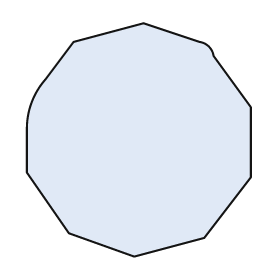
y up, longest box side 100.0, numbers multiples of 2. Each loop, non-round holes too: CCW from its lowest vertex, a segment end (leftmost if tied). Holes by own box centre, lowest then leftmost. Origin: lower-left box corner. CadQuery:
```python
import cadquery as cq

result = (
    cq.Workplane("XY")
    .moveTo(46.0, 0.0)
    .lineTo(76.0, 8.0)
    .lineTo(96.0, 34.0)
    .lineTo(96.0, 64.0)
    .lineTo(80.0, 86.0)
    .threePointArc((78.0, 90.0), (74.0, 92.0))
    .lineTo(50.0, 100.0)
    .lineTo(20.0, 92.0)
    .lineTo(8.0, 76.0)
    .threePointArc((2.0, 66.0), (0.0, 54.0))
    .lineTo(0.0, 36.0)
    .lineTo(18.0, 10.0)
    .close()
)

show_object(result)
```